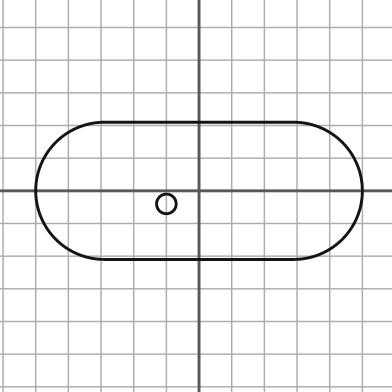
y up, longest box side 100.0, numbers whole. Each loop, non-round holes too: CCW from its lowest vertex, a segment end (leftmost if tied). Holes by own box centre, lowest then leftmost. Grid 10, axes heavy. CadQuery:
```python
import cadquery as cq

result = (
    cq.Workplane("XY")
    .moveTo(-29.0, -21.0)
    .lineTo(29.0, -21.0)
    .threePointArc((50.0, 0.0), (29.0, 21.0))
    .lineTo(-29.0, 21.0)
    .threePointArc((-50.0, 0.0), (-29.0, -21.0))
    .close()
    .moveTo(-10.0, -4.0)
    .circle(3.0)
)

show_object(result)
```